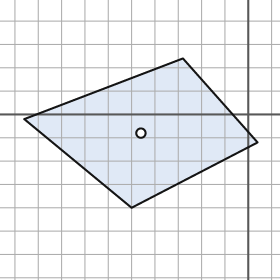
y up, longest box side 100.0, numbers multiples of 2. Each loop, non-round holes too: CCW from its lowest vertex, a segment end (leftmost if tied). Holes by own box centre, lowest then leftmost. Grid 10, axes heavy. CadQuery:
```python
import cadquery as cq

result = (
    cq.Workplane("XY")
    .moveTo(-50.0, -40.0)
    .lineTo(4.0, -12.0)
    .lineTo(-28.0, 24.0)
    .lineTo(-96.0, -2.0)
    .close()
    .moveTo(-46.0, -8.0)
    .circle(2.0)
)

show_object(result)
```